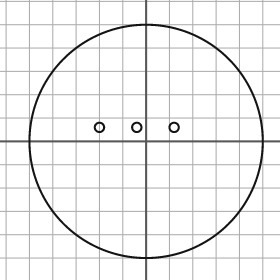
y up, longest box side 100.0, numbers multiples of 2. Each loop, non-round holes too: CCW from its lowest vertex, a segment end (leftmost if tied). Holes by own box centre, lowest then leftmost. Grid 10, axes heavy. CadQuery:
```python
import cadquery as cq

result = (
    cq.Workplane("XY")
    .moveTo(0.0, 0.0)
    .circle(50.0)
    .moveTo(-20.0, 6.0)
    .circle(2.0)
    .moveTo(-4.0, 6.0)
    .circle(2.0)
    .moveTo(12.0, 6.0)
    .circle(2.0)
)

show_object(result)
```